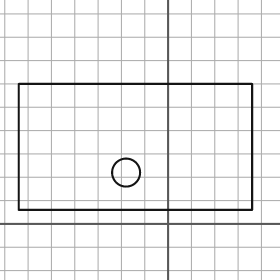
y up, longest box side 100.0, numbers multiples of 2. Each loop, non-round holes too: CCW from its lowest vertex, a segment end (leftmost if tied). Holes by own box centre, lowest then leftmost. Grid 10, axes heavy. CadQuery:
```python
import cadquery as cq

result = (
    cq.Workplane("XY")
    .moveTo(-64.0, 6.0)
    .lineTo(36.0, 6.0)
    .lineTo(36.0, 60.0)
    .lineTo(-64.0, 60.0)
    .close()
    .moveTo(-18.0, 22.0)
    .circle(6.0)
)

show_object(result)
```